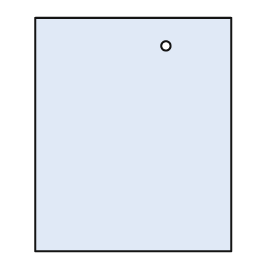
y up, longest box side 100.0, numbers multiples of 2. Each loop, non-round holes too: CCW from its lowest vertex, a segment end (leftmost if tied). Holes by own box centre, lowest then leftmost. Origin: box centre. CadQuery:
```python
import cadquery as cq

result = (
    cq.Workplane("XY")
    .moveTo(-42.0, -50.0)
    .lineTo(42.0, -50.0)
    .lineTo(42.0, 50.0)
    .lineTo(-42.0, 50.0)
    .close()
    .moveTo(14.0, 38.0)
    .circle(2.0)
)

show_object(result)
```